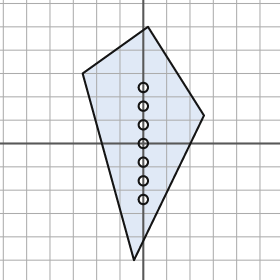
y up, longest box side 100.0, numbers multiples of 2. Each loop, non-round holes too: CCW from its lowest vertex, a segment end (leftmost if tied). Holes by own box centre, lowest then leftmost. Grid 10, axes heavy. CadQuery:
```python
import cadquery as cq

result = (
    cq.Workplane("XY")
    .moveTo(-4.0, -50.0)
    .lineTo(26.0, 12.0)
    .lineTo(2.0, 50.0)
    .lineTo(-26.0, 30.0)
    .close()
    .moveTo(0.0, -24.0)
    .circle(2.0)
    .moveTo(0.0, -16.0)
    .circle(2.0)
    .moveTo(0.0, -8.0)
    .circle(2.0)
    .moveTo(0.0, 0.0)
    .circle(2.0)
    .moveTo(0.0, 8.0)
    .circle(2.0)
    .moveTo(0.0, 16.0)
    .circle(2.0)
    .moveTo(0.0, 24.0)
    .circle(2.0)
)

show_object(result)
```